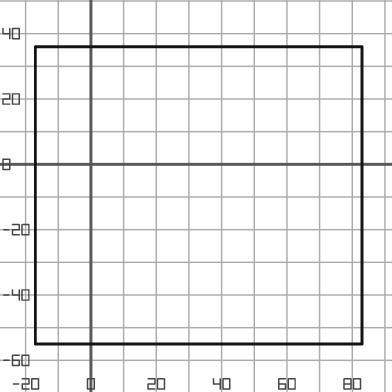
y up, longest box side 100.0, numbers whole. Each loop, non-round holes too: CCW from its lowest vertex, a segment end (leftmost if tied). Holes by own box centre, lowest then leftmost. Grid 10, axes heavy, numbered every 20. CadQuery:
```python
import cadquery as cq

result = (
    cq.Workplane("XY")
    .moveTo(-17.0, -55.0)
    .lineTo(83.0, -55.0)
    .lineTo(83.0, 36.0)
    .lineTo(-17.0, 36.0)
    .close()
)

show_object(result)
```